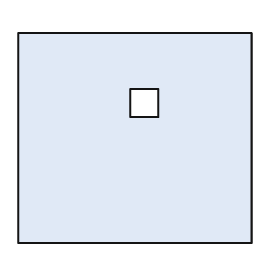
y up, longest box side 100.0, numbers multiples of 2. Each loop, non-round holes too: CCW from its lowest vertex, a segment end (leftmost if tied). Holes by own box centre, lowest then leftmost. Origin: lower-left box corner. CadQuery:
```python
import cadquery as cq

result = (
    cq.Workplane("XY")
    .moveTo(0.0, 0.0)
    .lineTo(100.0, 0.0)
    .lineTo(100.0, 90.0)
    .lineTo(0.0, 90.0)
    .close()
    .moveTo(48.0, 54.0)
    .lineTo(60.0, 54.0)
    .lineTo(60.0, 66.0)
    .lineTo(48.0, 66.0)
    .close()
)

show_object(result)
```